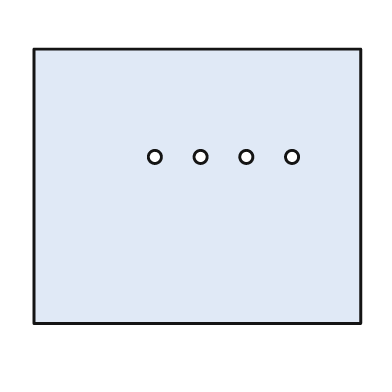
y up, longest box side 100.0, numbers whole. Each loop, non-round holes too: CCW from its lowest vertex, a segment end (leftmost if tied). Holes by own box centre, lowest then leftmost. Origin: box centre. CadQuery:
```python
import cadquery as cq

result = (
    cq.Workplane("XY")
    .moveTo(-50.0, -42.0)
    .lineTo(50.0, -42.0)
    .lineTo(50.0, 42.0)
    .lineTo(-50.0, 42.0)
    .close()
    .moveTo(-13.0, 9.0)
    .circle(2.0)
    .moveTo(1.0, 9.0)
    .circle(2.0)
    .moveTo(15.0, 9.0)
    .circle(2.0)
    .moveTo(29.0, 9.0)
    .circle(2.0)
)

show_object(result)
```